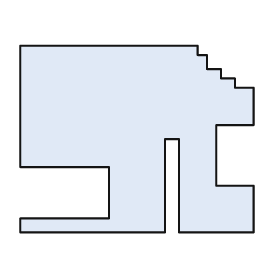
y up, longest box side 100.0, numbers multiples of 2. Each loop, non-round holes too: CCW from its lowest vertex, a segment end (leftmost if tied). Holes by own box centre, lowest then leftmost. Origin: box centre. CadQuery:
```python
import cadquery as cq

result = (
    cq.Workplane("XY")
    .moveTo(-50.0, -40.0)
    .lineTo(12.0, -40.0)
    .lineTo(12.0, 0.0)
    .lineTo(18.0, 0.0)
    .lineTo(18.0, -40.0)
    .lineTo(50.0, -40.0)
    .lineTo(50.0, -20.0)
    .lineTo(34.0, -20.0)
    .lineTo(34.0, 6.0)
    .lineTo(50.0, 6.0)
    .lineTo(50.0, 22.0)
    .lineTo(42.0, 22.0)
    .lineTo(42.0, 26.0)
    .lineTo(36.0, 26.0)
    .lineTo(36.0, 30.0)
    .lineTo(30.0, 30.0)
    .lineTo(30.0, 36.0)
    .lineTo(26.0, 36.0)
    .lineTo(26.0, 40.0)
    .lineTo(-50.0, 40.0)
    .lineTo(-50.0, -12.0)
    .lineTo(-12.0, -12.0)
    .lineTo(-12.0, -34.0)
    .lineTo(-50.0, -34.0)
    .close()
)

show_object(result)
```